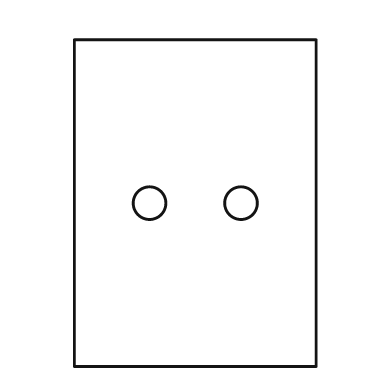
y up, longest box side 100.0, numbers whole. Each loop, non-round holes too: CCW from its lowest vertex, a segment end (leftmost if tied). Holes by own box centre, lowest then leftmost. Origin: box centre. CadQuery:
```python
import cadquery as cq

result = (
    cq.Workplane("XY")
    .moveTo(-37.0, -50.0)
    .lineTo(37.0, -50.0)
    .lineTo(37.0, 50.0)
    .lineTo(-37.0, 50.0)
    .close()
    .moveTo(-14.0, 0.0)
    .circle(5.0)
    .moveTo(14.0, 0.0)
    .circle(5.0)
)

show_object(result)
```